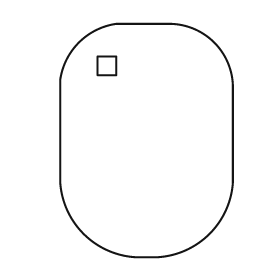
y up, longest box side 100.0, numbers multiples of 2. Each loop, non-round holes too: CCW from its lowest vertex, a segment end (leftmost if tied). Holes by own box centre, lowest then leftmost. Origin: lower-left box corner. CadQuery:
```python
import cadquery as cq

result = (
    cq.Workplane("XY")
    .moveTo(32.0, 0.0)
    .lineTo(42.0, 0.0)
    .threePointArc((64.0, 10.0), (74.0, 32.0))
    .lineTo(74.0, 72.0)
    .threePointArc((66.0, 92.0), (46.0, 100.0))
    .lineTo(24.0, 100.0)
    .threePointArc((8.0, 92.0), (0.0, 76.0))
    .lineTo(0.0, 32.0)
    .threePointArc((10.0, 10.0), (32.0, 0.0))
    .close()
    .moveTo(16.0, 78.0)
    .lineTo(24.0, 78.0)
    .lineTo(24.0, 86.0)
    .lineTo(16.0, 86.0)
    .close()
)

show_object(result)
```